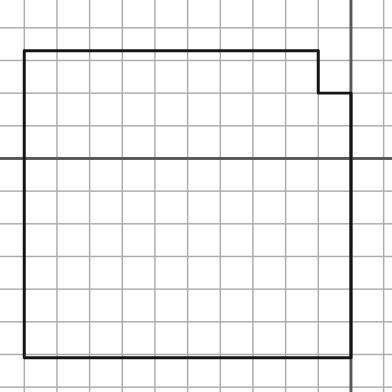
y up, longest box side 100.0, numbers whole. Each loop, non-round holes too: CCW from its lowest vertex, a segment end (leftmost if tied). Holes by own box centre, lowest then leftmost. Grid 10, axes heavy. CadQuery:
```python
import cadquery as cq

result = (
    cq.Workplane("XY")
    .moveTo(-100.0, -61.0)
    .lineTo(0.0, -61.0)
    .lineTo(0.0, 20.0)
    .lineTo(-10.0, 20.0)
    .lineTo(-10.0, 33.0)
    .lineTo(-100.0, 33.0)
    .close()
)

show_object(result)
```